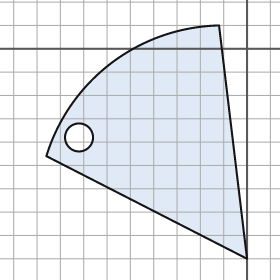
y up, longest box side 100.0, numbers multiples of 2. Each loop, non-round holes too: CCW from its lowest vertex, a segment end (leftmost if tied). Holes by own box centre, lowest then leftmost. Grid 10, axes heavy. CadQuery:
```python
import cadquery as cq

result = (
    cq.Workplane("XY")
    .moveTo(0.0, -90.0)
    .lineTo(-12.0, 10.0)
    .threePointArc((-58.0, -6.0), (-86.0, -46.0))
    .close()
    .moveTo(-72.0, -38.0)
    .circle(6.0)
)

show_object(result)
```